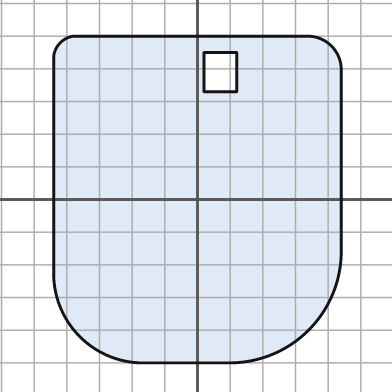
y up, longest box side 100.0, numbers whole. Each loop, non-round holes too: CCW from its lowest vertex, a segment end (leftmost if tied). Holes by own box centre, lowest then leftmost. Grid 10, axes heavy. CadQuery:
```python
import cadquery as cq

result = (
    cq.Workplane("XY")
    .moveTo(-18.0, -50.0)
    .lineTo(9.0, -50.0)
    .threePointArc((34.0, -40.0), (44.0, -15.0))
    .lineTo(44.0, 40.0)
    .threePointArc((41.0, 47.0), (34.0, 50.0))
    .lineTo(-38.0, 50.0)
    .threePointArc((-42.0, 48.0), (-44.0, 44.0))
    .lineTo(-44.0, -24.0)
    .threePointArc((-36.0, -42.0), (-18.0, -50.0))
    .close()
    .moveTo(2.0, 33.0)
    .lineTo(12.0, 33.0)
    .lineTo(12.0, 45.0)
    .lineTo(2.0, 45.0)
    .close()
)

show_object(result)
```